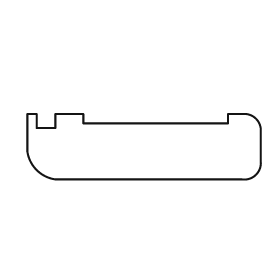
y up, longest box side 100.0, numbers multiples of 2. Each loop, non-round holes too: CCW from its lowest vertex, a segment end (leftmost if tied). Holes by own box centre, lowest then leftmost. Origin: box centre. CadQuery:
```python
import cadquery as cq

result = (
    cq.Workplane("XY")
    .moveTo(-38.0, -14.0)
    .lineTo(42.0, -14.0)
    .threePointArc((48.0, -12.0), (50.0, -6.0))
    .lineTo(50.0, 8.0)
    .threePointArc((48.0, 12.0), (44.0, 14.0))
    .lineTo(36.0, 14.0)
    .lineTo(36.0, 10.0)
    .lineTo(-26.0, 10.0)
    .lineTo(-26.0, 14.0)
    .lineTo(-38.0, 14.0)
    .lineTo(-38.0, 8.0)
    .lineTo(-46.0, 8.0)
    .lineTo(-46.0, 14.0)
    .lineTo(-50.0, 14.0)
    .lineTo(-50.0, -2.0)
    .threePointArc((-46.0, -10.0), (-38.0, -14.0))
    .close()
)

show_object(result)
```